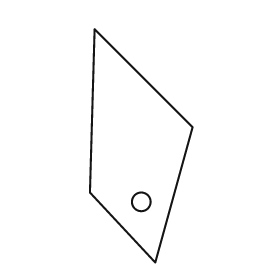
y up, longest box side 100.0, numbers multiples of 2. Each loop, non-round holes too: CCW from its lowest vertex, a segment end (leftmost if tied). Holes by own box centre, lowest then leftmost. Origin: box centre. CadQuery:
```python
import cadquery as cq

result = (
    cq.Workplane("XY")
    .moveTo(6.0, -50.0)
    .lineTo(22.0, 8.0)
    .lineTo(-20.0, 50.0)
    .lineTo(-22.0, -20.0)
    .close()
    .moveTo(0.0, -24.0)
    .circle(4.0)
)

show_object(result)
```